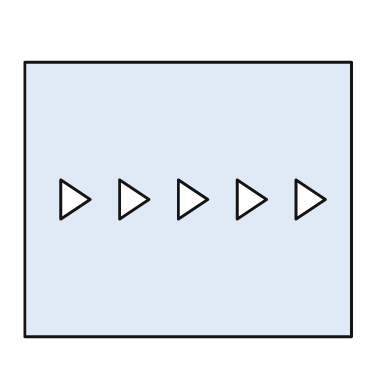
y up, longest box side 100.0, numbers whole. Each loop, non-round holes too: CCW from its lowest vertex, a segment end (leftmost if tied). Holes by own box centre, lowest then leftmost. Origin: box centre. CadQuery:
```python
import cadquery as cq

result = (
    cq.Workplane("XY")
    .moveTo(-50.0, -42.0)
    .lineTo(50.0, -42.0)
    .lineTo(50.0, 42.0)
    .lineTo(-50.0, 42.0)
    .close()
    .moveTo(-39.0, -6.0)
    .lineTo(-30.0, 0.0)
    .lineTo(-39.0, 6.0)
    .close()
    .moveTo(-21.0, -6.0)
    .lineTo(-12.0, 0.0)
    .lineTo(-21.0, 6.0)
    .close()
    .moveTo(-3.0, -6.0)
    .lineTo(6.0, 0.0)
    .lineTo(-3.0, 6.0)
    .close()
    .moveTo(15.0, -6.0)
    .lineTo(24.0, 0.0)
    .lineTo(15.0, 6.0)
    .close()
    .moveTo(33.0, -6.0)
    .lineTo(42.0, 0.0)
    .lineTo(33.0, 6.0)
    .close()
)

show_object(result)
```